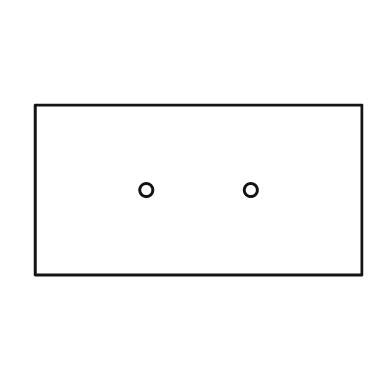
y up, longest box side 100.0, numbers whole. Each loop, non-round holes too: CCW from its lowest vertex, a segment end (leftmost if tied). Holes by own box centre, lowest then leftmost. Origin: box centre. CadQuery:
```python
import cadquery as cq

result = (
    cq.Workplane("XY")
    .moveTo(-50.0, -26.0)
    .lineTo(50.0, -26.0)
    .lineTo(50.0, 26.0)
    .lineTo(-50.0, 26.0)
    .close()
    .moveTo(-16.0, 0.0)
    .circle(2.0)
    .moveTo(16.0, 0.0)
    .circle(2.0)
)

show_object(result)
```